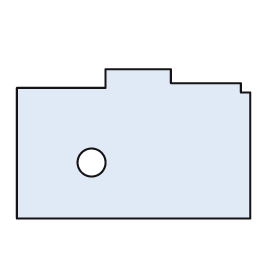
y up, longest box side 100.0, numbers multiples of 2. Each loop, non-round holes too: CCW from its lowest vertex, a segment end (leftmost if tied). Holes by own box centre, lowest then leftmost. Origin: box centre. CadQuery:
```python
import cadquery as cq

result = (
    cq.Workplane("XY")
    .moveTo(-50.0, -32.0)
    .lineTo(50.0, -32.0)
    .lineTo(50.0, 22.0)
    .lineTo(46.0, 22.0)
    .lineTo(46.0, 26.0)
    .lineTo(16.0, 26.0)
    .lineTo(16.0, 32.0)
    .lineTo(-12.0, 32.0)
    .lineTo(-12.0, 24.0)
    .lineTo(-50.0, 24.0)
    .close()
    .moveTo(-18.0, -8.0)
    .circle(6.0)
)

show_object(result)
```